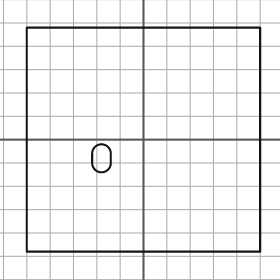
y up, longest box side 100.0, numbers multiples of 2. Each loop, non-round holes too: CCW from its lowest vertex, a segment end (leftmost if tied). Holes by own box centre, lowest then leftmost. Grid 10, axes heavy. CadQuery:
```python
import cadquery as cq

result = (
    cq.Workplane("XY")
    .moveTo(-50.0, -48.0)
    .lineTo(50.0, -48.0)
    .lineTo(50.0, 48.0)
    .lineTo(-50.0, 48.0)
    .close()
    .moveTo(-22.0, -10.0)
    .threePointArc((-18.0, -14.0), (-14.0, -10.0))
    .lineTo(-14.0, -6.0)
    .threePointArc((-18.0, -2.0), (-22.0, -6.0))
    .close()
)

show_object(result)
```